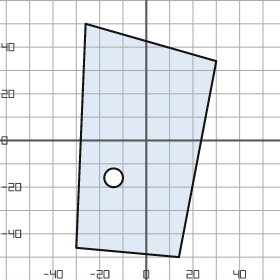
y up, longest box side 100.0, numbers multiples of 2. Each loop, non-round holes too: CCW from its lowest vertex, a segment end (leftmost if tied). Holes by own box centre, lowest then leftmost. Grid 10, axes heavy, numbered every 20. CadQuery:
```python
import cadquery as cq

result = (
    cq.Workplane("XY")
    .moveTo(14.0, -50.0)
    .lineTo(30.0, 34.0)
    .lineTo(-26.0, 50.0)
    .lineTo(-30.0, -46.0)
    .close()
    .moveTo(-14.0, -16.0)
    .circle(4.0)
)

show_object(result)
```